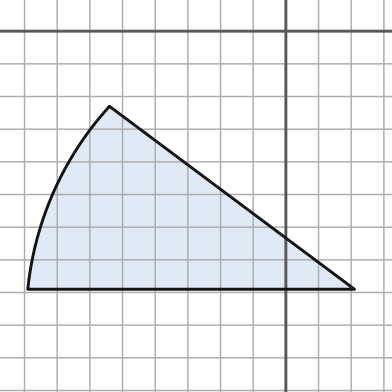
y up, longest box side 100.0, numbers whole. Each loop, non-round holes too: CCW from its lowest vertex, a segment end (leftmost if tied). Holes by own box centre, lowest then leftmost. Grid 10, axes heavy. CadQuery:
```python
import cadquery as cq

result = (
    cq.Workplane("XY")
    .moveTo(-79.0, -79.0)
    .lineTo(21.0, -79.0)
    .lineTo(-54.0, -23.0)
    .threePointArc((-71.0, -49.0), (-79.0, -79.0))
    .close()
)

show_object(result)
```